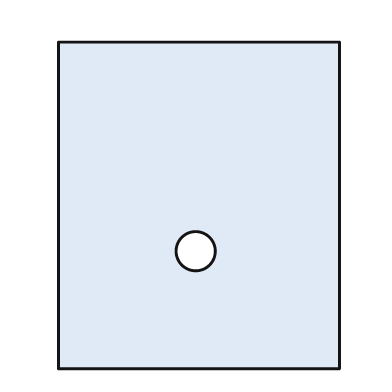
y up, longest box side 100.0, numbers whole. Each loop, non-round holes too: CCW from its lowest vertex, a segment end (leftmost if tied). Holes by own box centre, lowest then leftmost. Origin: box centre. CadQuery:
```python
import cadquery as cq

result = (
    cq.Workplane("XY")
    .moveTo(-43.0, -50.0)
    .lineTo(43.0, -50.0)
    .lineTo(43.0, 50.0)
    .lineTo(-43.0, 50.0)
    .close()
    .moveTo(-1.0, -14.0)
    .circle(6.0)
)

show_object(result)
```